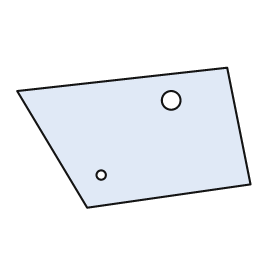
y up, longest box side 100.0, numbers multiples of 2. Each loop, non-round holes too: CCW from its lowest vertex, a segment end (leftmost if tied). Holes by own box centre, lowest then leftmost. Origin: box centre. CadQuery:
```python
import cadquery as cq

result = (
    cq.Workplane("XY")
    .moveTo(-20.0, -30.0)
    .lineTo(50.0, -20.0)
    .lineTo(40.0, 30.0)
    .lineTo(-50.0, 20.0)
    .close()
    .moveTo(-14.0, -16.0)
    .circle(2.0)
    .moveTo(16.0, 16.0)
    .circle(4.0)
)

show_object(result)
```